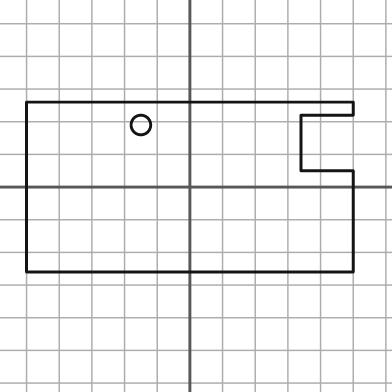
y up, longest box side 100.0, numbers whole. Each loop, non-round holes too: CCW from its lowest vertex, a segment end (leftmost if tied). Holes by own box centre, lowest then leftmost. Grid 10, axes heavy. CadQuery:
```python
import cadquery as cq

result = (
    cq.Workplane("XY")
    .moveTo(-50.0, -26.0)
    .lineTo(50.0, -26.0)
    .lineTo(50.0, 5.0)
    .lineTo(34.0, 5.0)
    .lineTo(34.0, 22.0)
    .lineTo(50.0, 22.0)
    .lineTo(50.0, 26.0)
    .lineTo(-50.0, 26.0)
    .close()
    .moveTo(-15.0, 19.0)
    .circle(3.0)
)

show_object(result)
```